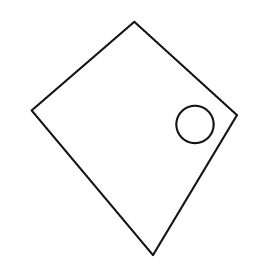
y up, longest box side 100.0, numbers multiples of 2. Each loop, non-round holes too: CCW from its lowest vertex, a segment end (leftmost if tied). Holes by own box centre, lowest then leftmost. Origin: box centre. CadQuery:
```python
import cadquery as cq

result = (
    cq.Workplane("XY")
    .moveTo(8.0, -50.0)
    .lineTo(44.0, 10.0)
    .lineTo(0.0, 50.0)
    .lineTo(-44.0, 12.0)
    .close()
    .moveTo(26.0, 6.0)
    .circle(8.0)
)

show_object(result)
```